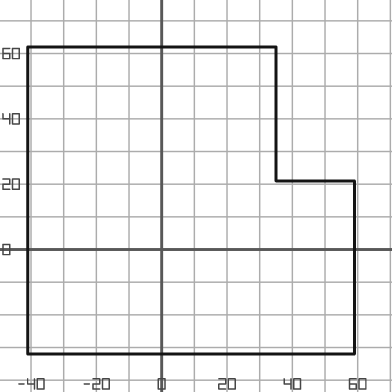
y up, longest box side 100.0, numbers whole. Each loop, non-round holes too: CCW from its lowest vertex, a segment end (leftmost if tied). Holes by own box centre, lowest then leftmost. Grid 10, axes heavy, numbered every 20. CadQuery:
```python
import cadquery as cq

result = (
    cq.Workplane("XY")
    .moveTo(-41.0, -32.0)
    .lineTo(59.0, -32.0)
    .lineTo(59.0, 21.0)
    .lineTo(35.0, 21.0)
    .lineTo(35.0, 62.0)
    .lineTo(-41.0, 62.0)
    .close()
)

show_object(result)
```